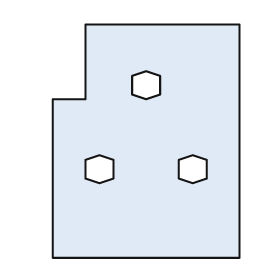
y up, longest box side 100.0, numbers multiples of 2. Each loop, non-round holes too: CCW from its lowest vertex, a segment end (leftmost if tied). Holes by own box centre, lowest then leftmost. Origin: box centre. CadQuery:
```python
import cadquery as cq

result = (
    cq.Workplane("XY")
    .moveTo(-40.0, -50.0)
    .lineTo(40.0, -50.0)
    .lineTo(40.0, 50.0)
    .lineTo(-26.0, 50.0)
    .lineTo(-26.0, 18.0)
    .lineTo(-40.0, 18.0)
    .close()
    .moveTo(-20.0, -18.0)
    .lineTo(-14.0, -16.0)
    .lineTo(-14.0, -8.0)
    .lineTo(-20.0, -6.0)
    .lineTo(-26.0, -8.0)
    .lineTo(-26.0, -16.0)
    .close()
    .moveTo(20.0, -18.0)
    .lineTo(26.0, -16.0)
    .lineTo(26.0, -8.0)
    .lineTo(20.0, -6.0)
    .lineTo(14.0, -8.0)
    .lineTo(14.0, -16.0)
    .close()
    .moveTo(0.0, 18.0)
    .lineTo(6.0, 20.0)
    .lineTo(6.0, 28.0)
    .lineTo(0.0, 30.0)
    .lineTo(-6.0, 28.0)
    .lineTo(-6.0, 20.0)
    .close()
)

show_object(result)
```